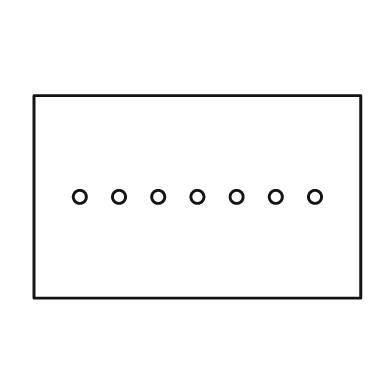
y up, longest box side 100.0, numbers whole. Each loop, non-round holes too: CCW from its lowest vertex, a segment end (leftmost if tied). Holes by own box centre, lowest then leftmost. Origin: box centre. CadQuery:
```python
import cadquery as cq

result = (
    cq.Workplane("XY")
    .moveTo(-50.0, -31.0)
    .lineTo(50.0, -31.0)
    .lineTo(50.0, 31.0)
    .lineTo(-50.0, 31.0)
    .close()
    .moveTo(-36.0, 0.0)
    .circle(2.0)
    .moveTo(-24.0, 0.0)
    .circle(2.0)
    .moveTo(-12.0, 0.0)
    .circle(2.0)
    .moveTo(0.0, 0.0)
    .circle(2.0)
    .moveTo(12.0, 0.0)
    .circle(2.0)
    .moveTo(24.0, 0.0)
    .circle(2.0)
    .moveTo(36.0, 0.0)
    .circle(2.0)
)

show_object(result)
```